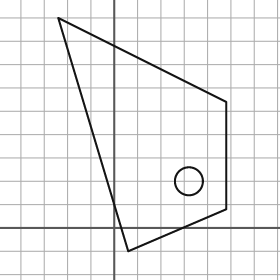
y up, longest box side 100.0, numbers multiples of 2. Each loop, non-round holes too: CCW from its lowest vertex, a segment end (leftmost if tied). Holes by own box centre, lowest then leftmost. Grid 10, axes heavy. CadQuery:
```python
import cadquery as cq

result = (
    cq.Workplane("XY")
    .moveTo(6.0, -10.0)
    .lineTo(48.0, 8.0)
    .lineTo(48.0, 54.0)
    .lineTo(-24.0, 90.0)
    .close()
    .moveTo(32.0, 20.0)
    .circle(6.0)
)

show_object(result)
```